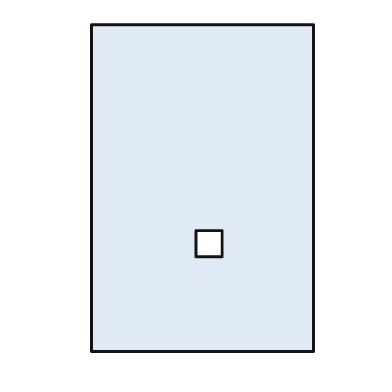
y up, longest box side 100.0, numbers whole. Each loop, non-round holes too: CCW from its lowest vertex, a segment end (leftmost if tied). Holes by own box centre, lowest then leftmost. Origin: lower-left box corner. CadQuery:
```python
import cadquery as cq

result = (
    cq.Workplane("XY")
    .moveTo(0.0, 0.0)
    .lineTo(68.0, 0.0)
    .lineTo(68.0, 100.0)
    .lineTo(0.0, 100.0)
    .close()
    .moveTo(32.0, 29.0)
    .lineTo(40.0, 29.0)
    .lineTo(40.0, 37.0)
    .lineTo(32.0, 37.0)
    .close()
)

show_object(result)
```